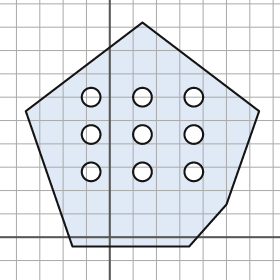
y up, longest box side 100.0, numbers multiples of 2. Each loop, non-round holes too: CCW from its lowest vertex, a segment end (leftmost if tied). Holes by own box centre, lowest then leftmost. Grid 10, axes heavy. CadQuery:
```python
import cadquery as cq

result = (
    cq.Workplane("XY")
    .moveTo(-16.0, -4.0)
    .lineTo(34.0, -4.0)
    .lineTo(50.0, 14.0)
    .lineTo(64.0, 54.0)
    .lineTo(14.0, 92.0)
    .lineTo(-36.0, 54.0)
    .close()
    .moveTo(-8.0, 28.0)
    .circle(4.0)
    .moveTo(14.0, 28.0)
    .circle(4.0)
    .moveTo(36.0, 28.0)
    .circle(4.0)
    .moveTo(-8.0, 44.0)
    .circle(4.0)
    .moveTo(14.0, 44.0)
    .circle(4.0)
    .moveTo(36.0, 44.0)
    .circle(4.0)
    .moveTo(-8.0, 60.0)
    .circle(4.0)
    .moveTo(14.0, 60.0)
    .circle(4.0)
    .moveTo(36.0, 60.0)
    .circle(4.0)
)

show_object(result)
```